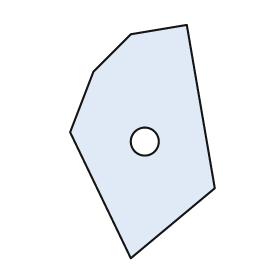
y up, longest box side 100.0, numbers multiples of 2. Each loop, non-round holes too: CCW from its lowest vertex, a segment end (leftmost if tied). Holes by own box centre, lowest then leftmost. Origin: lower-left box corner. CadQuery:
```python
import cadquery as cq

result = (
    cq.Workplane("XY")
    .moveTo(26.0, 0.0)
    .lineTo(62.0, 30.0)
    .lineTo(50.0, 100.0)
    .lineTo(26.0, 96.0)
    .lineTo(10.0, 80.0)
    .lineTo(0.0, 54.0)
    .close()
    .moveTo(32.0, 50.0)
    .circle(6.0)
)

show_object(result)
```